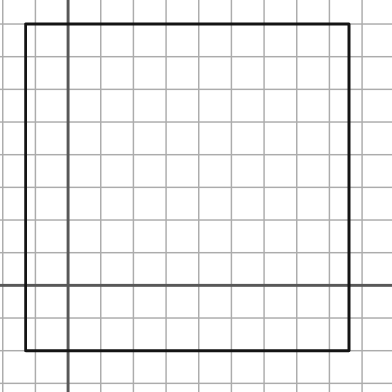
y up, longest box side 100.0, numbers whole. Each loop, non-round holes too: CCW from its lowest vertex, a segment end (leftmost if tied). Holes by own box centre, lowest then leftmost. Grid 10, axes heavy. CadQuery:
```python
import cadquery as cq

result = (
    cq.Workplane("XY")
    .moveTo(-13.0, -20.0)
    .lineTo(86.0, -20.0)
    .lineTo(86.0, 80.0)
    .lineTo(-13.0, 80.0)
    .close()
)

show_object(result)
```